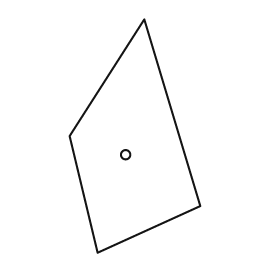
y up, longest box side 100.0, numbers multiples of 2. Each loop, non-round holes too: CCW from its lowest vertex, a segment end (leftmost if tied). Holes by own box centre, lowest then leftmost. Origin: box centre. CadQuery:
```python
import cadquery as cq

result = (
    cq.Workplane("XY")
    .moveTo(-16.0, -50.0)
    .lineTo(28.0, -30.0)
    .lineTo(4.0, 50.0)
    .lineTo(-28.0, 0.0)
    .close()
    .moveTo(-4.0, -8.0)
    .circle(2.0)
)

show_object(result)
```